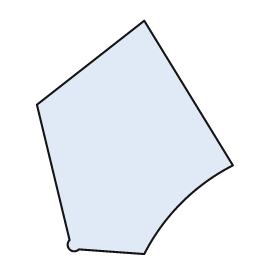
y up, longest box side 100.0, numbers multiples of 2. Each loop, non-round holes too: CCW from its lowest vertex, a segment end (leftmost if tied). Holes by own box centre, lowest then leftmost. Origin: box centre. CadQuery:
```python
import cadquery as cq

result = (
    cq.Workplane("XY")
    .moveTo(4.0, -50.0)
    .threePointArc((20.0, -28.0), (42.0, -12.0))
    .lineTo(4.0, 50.0)
    .lineTo(-42.0, 14.0)
    .lineTo(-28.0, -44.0)
    .threePointArc((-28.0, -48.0), (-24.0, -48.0))
    .close()
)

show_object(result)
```